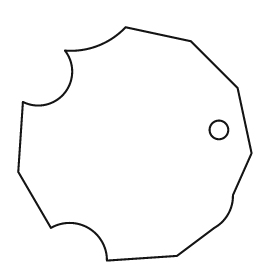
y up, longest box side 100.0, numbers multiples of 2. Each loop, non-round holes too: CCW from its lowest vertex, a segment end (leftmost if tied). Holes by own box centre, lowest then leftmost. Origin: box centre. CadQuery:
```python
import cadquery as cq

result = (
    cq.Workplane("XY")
    .moveTo(-12.0, -50.0)
    .lineTo(18.0, -48.0)
    .lineTo(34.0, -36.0)
    .threePointArc((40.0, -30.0), (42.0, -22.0))
    .lineTo(50.0, -4.0)
    .lineTo(44.0, 24.0)
    .lineTo(24.0, 44.0)
    .lineTo(-4.0, 50.0)
    .threePointArc((-16.0, 42.0), (-30.0, 40.0))
    .threePointArc((-30.0, 22.0), (-48.0, 18.0))
    .lineTo(-50.0, -12.0)
    .lineTo(-36.0, -36.0)
    .threePointArc((-20.0, -36.0), (-12.0, -50.0))
    .close()
    .moveTo(36.0, 6.0)
    .circle(4.0)
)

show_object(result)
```